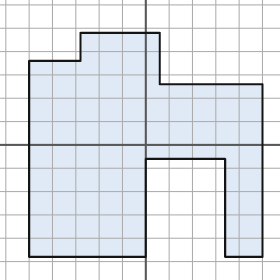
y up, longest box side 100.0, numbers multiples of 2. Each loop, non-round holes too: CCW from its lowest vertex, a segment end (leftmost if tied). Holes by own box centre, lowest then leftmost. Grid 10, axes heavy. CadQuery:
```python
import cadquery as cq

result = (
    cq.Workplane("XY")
    .moveTo(-50.0, -48.0)
    .lineTo(0.0, -48.0)
    .lineTo(0.0, -6.0)
    .lineTo(34.0, -6.0)
    .lineTo(34.0, -48.0)
    .lineTo(50.0, -48.0)
    .lineTo(50.0, 26.0)
    .lineTo(6.0, 26.0)
    .lineTo(6.0, 48.0)
    .lineTo(-28.0, 48.0)
    .lineTo(-28.0, 36.0)
    .lineTo(-50.0, 36.0)
    .close()
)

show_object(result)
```